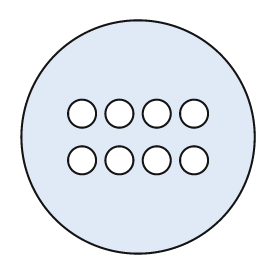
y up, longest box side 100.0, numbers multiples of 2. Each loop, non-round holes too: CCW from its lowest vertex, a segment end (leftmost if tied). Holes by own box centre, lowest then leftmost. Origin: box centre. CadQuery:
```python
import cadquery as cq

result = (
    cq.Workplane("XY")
    .moveTo(0.0, 0.0)
    .circle(50.0)
    .moveTo(-24.0, -10.0)
    .circle(6.0)
    .moveTo(-8.0, -10.0)
    .circle(6.0)
    .moveTo(8.0, -10.0)
    .circle(6.0)
    .moveTo(24.0, -10.0)
    .circle(6.0)
    .moveTo(-24.0, 10.0)
    .circle(6.0)
    .moveTo(-8.0, 10.0)
    .circle(6.0)
    .moveTo(8.0, 10.0)
    .circle(6.0)
    .moveTo(24.0, 10.0)
    .circle(6.0)
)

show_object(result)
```